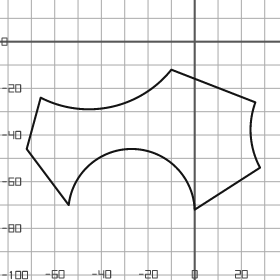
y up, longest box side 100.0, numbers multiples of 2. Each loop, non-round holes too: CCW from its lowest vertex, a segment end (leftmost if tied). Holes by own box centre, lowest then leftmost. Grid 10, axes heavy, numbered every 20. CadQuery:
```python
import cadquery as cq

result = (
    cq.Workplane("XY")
    .moveTo(0.0, -72.0)
    .lineTo(28.0, -54.0)
    .threePointArc((24.0, -40.0), (26.0, -26.0))
    .lineTo(-10.0, -12.0)
    .threePointArc((-36.0, -28.0), (-66.0, -24.0))
    .lineTo(-72.0, -46.0)
    .lineTo(-54.0, -70.0)
    .threePointArc((-26.0, -46.0), (0.0, -72.0))
    .close()
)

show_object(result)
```